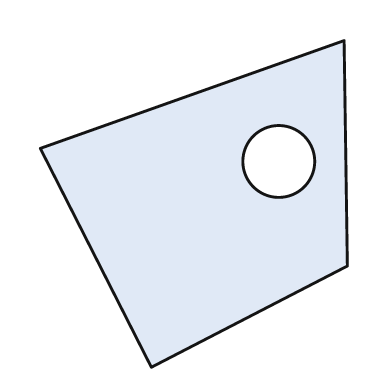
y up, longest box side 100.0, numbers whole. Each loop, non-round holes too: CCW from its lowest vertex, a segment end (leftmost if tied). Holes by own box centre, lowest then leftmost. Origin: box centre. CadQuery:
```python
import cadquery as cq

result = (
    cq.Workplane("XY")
    .moveTo(-13.0, -50.0)
    .lineTo(47.0, -19.0)
    .lineTo(46.0, 50.0)
    .lineTo(-47.0, 17.0)
    .close()
    .moveTo(26.0, 13.0)
    .circle(11.0)
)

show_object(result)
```